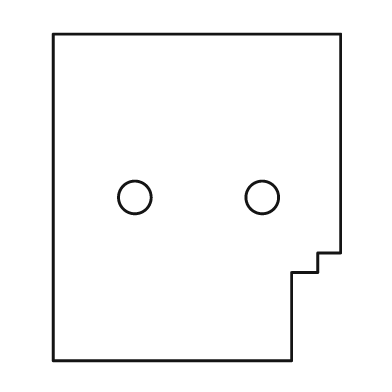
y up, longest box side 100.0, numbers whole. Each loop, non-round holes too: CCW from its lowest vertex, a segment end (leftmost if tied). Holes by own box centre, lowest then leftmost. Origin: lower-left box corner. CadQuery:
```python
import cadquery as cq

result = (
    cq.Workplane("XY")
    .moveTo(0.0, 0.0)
    .lineTo(73.0, 0.0)
    .lineTo(73.0, 27.0)
    .lineTo(81.0, 27.0)
    .lineTo(81.0, 33.0)
    .lineTo(88.0, 33.0)
    .lineTo(88.0, 100.0)
    .lineTo(0.0, 100.0)
    .close()
    .moveTo(25.0, 50.0)
    .circle(5.0)
    .moveTo(64.0, 50.0)
    .circle(5.0)
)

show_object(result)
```